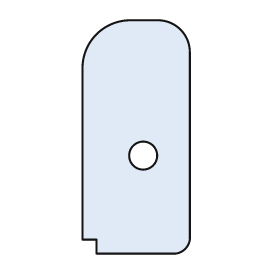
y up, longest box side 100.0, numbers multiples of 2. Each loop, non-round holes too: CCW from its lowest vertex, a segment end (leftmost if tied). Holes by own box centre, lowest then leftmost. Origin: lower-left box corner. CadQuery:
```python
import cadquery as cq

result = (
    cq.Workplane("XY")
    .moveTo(6.0, 0.0)
    .lineTo(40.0, 0.0)
    .threePointArc((44.0, 2.0), (46.0, 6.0))
    .lineTo(46.0, 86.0)
    .threePointArc((42.0, 96.0), (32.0, 100.0))
    .lineTo(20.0, 100.0)
    .threePointArc((6.0, 94.0), (0.0, 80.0))
    .lineTo(0.0, 6.0)
    .lineTo(6.0, 6.0)
    .close()
    .moveTo(26.0, 42.0)
    .circle(6.0)
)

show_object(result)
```